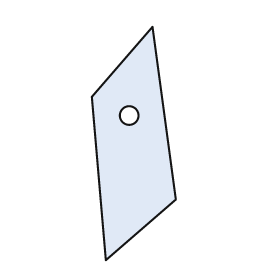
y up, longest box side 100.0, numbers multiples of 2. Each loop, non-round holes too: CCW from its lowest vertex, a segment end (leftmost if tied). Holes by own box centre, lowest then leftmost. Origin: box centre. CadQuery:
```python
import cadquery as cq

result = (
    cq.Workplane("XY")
    .moveTo(-12.0, -50.0)
    .lineTo(18.0, -24.0)
    .lineTo(8.0, 50.0)
    .lineTo(-18.0, 20.0)
    .close()
    .moveTo(-2.0, 12.0)
    .circle(4.0)
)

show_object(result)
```